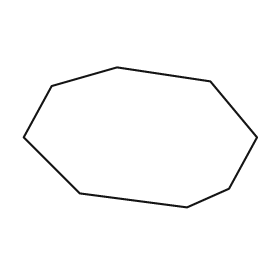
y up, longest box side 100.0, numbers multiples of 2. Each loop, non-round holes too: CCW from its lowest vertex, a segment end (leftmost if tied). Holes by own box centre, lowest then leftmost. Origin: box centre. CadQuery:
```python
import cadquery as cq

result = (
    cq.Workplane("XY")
    .moveTo(20.0, -30.0)
    .lineTo(38.0, -22.0)
    .lineTo(50.0, 0.0)
    .lineTo(30.0, 24.0)
    .lineTo(-10.0, 30.0)
    .lineTo(-38.0, 22.0)
    .lineTo(-50.0, 0.0)
    .lineTo(-26.0, -24.0)
    .close()
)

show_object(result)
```